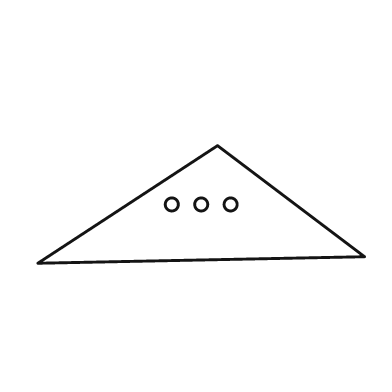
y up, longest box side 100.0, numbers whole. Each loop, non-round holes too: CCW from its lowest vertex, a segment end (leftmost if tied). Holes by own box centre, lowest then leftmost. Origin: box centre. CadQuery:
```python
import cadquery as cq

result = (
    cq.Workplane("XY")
    .moveTo(-50.0, -18.0)
    .lineTo(50.0, -16.0)
    .lineTo(5.0, 18.0)
    .close()
    .moveTo(-9.0, 0.0)
    .circle(2.0)
    .moveTo(0.0, 0.0)
    .circle(2.0)
    .moveTo(9.0, 0.0)
    .circle(2.0)
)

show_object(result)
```